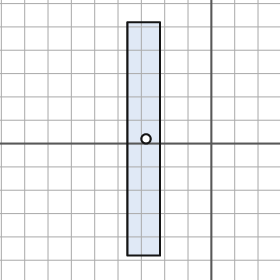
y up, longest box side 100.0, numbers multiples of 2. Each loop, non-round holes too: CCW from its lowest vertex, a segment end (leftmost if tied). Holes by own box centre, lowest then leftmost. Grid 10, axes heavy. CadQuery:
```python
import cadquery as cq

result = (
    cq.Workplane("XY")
    .moveTo(-36.0, -48.0)
    .lineTo(-22.0, -48.0)
    .lineTo(-22.0, 52.0)
    .lineTo(-36.0, 52.0)
    .close()
    .moveTo(-28.0, 2.0)
    .circle(2.0)
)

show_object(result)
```